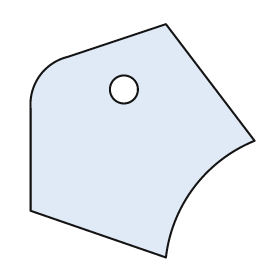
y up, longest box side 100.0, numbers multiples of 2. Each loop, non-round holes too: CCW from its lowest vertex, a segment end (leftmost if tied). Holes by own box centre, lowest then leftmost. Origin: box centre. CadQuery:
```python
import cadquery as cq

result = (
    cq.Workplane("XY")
    .moveTo(10.0, -50.0)
    .threePointArc((22.0, -20.0), (48.0, 0.0))
    .lineTo(10.0, 50.0)
    .lineTo(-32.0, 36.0)
    .threePointArc((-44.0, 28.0), (-48.0, 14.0))
    .lineTo(-48.0, -30.0)
    .close()
    .moveTo(-8.0, 22.0)
    .circle(6.0)
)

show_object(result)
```